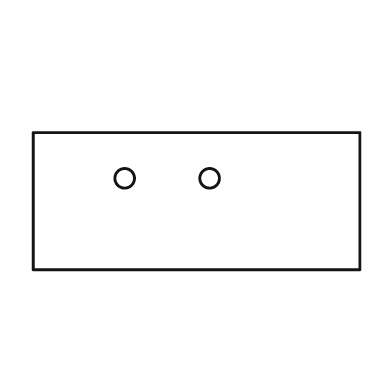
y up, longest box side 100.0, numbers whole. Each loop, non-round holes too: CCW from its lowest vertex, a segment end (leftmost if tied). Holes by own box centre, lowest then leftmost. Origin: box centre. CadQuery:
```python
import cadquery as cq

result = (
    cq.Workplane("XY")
    .moveTo(-50.0, -21.0)
    .lineTo(50.0, -21.0)
    .lineTo(50.0, 21.0)
    .lineTo(-50.0, 21.0)
    .close()
    .moveTo(-22.0, 7.0)
    .circle(3.0)
    .moveTo(4.0, 7.0)
    .circle(3.0)
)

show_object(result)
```